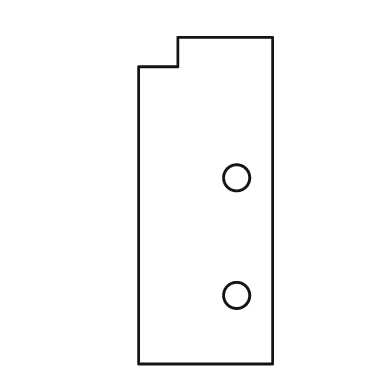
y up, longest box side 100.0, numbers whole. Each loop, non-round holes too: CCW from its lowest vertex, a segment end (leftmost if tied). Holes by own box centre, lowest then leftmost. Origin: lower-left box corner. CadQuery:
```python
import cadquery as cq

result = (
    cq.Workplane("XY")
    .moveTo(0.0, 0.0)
    .lineTo(41.0, 0.0)
    .lineTo(41.0, 100.0)
    .lineTo(12.0, 100.0)
    .lineTo(12.0, 91.0)
    .lineTo(0.0, 91.0)
    .close()
    .moveTo(30.0, 21.0)
    .circle(4.0)
    .moveTo(30.0, 57.0)
    .circle(4.0)
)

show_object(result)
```